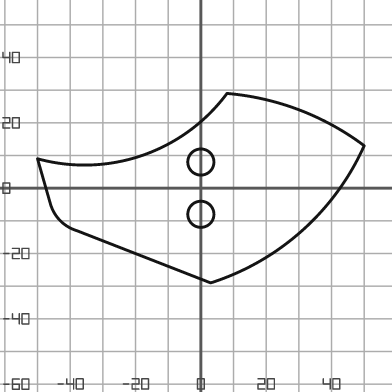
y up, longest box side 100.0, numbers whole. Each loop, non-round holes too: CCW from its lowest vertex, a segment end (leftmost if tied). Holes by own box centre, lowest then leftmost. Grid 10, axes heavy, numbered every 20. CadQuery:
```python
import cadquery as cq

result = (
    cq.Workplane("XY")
    .moveTo(3.0, -29.0)
    .threePointArc((31.0, -13.0), (50.0, 13.0))
    .threePointArc((30.0, 24.0), (8.0, 29.0))
    .threePointArc((-18.0, 10.0), (-50.0, 9.0))
    .lineTo(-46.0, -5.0)
    .threePointArc((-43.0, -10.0), (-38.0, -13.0))
    .close()
    .moveTo(0.0, -8.0)
    .circle(4.0)
    .moveTo(0.0, 8.0)
    .circle(4.0)
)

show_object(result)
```